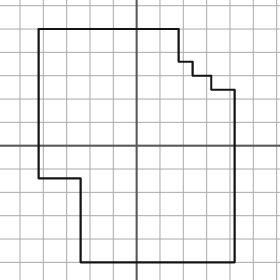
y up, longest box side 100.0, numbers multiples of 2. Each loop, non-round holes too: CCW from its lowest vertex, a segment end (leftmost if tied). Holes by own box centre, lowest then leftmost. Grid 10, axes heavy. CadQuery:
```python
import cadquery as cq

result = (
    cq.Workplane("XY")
    .moveTo(-24.0, -50.0)
    .lineTo(42.0, -50.0)
    .lineTo(42.0, 24.0)
    .lineTo(32.0, 24.0)
    .lineTo(32.0, 30.0)
    .lineTo(24.0, 30.0)
    .lineTo(24.0, 36.0)
    .lineTo(18.0, 36.0)
    .lineTo(18.0, 50.0)
    .lineTo(-42.0, 50.0)
    .lineTo(-42.0, -14.0)
    .lineTo(-24.0, -14.0)
    .close()
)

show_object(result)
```